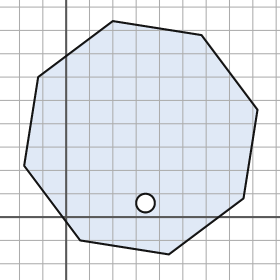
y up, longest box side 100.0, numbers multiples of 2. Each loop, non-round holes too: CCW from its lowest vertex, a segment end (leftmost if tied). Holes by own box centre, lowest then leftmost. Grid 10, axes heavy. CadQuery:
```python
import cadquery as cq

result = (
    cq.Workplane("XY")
    .moveTo(44.0, -16.0)
    .lineTo(76.0, 8.0)
    .lineTo(82.0, 46.0)
    .lineTo(58.0, 78.0)
    .lineTo(20.0, 84.0)
    .lineTo(-12.0, 60.0)
    .lineTo(-18.0, 22.0)
    .lineTo(6.0, -10.0)
    .close()
    .moveTo(34.0, 6.0)
    .circle(4.0)
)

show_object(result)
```